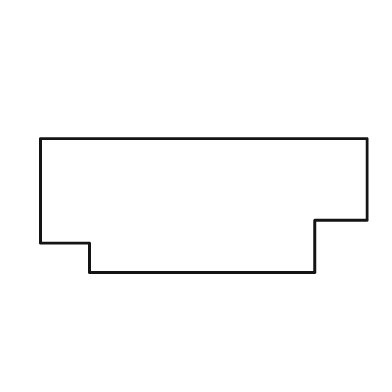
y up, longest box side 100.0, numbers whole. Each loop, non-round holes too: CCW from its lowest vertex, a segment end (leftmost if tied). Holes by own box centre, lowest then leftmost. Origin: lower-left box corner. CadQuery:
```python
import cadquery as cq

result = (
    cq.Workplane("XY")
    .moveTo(15.0, 0.0)
    .lineTo(84.0, 0.0)
    .lineTo(84.0, 16.0)
    .lineTo(100.0, 16.0)
    .lineTo(100.0, 41.0)
    .lineTo(0.0, 41.0)
    .lineTo(0.0, 9.0)
    .lineTo(15.0, 9.0)
    .close()
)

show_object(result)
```